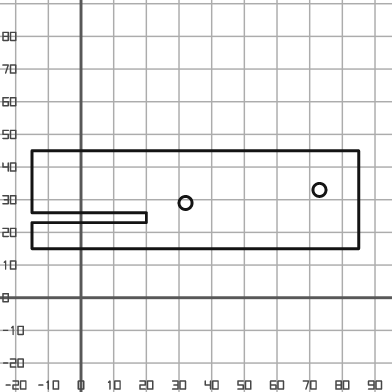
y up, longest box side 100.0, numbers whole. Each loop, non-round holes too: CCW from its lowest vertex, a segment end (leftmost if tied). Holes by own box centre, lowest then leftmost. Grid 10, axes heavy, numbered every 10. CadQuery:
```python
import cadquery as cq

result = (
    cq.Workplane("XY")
    .moveTo(-15.0, 15.0)
    .lineTo(85.0, 15.0)
    .lineTo(85.0, 45.0)
    .lineTo(-15.0, 45.0)
    .lineTo(-15.0, 26.0)
    .lineTo(20.0, 26.0)
    .lineTo(20.0, 23.0)
    .lineTo(-15.0, 23.0)
    .close()
    .moveTo(32.0, 29.0)
    .circle(2.0)
    .moveTo(73.0, 33.0)
    .circle(2.0)
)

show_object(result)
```